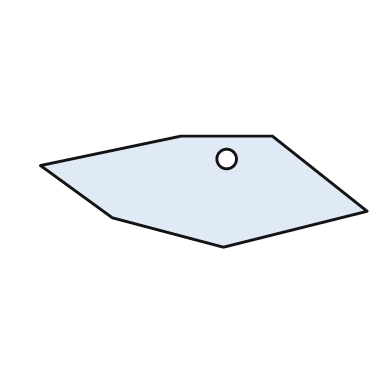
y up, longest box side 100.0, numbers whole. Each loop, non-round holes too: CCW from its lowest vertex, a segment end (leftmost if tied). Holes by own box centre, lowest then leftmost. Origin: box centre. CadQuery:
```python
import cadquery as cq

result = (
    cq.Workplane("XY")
    .moveTo(6.0, -17.0)
    .lineTo(50.0, -6.0)
    .lineTo(21.0, 17.0)
    .lineTo(-7.0, 17.0)
    .lineTo(-50.0, 8.0)
    .lineTo(-28.0, -8.0)
    .close()
    .moveTo(7.0, 10.0)
    .circle(3.0)
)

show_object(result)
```